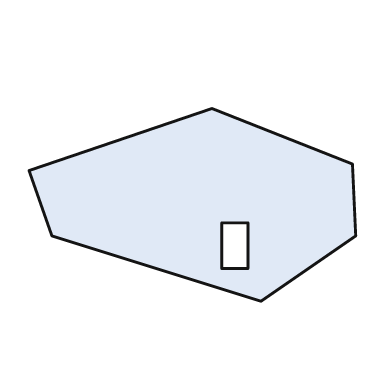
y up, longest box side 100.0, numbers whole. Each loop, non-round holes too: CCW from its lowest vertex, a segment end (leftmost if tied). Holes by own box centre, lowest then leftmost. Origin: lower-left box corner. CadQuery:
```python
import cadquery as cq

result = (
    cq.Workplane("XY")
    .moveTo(71.0, 0.0)
    .lineTo(100.0, 20.0)
    .lineTo(99.0, 42.0)
    .lineTo(56.0, 59.0)
    .lineTo(0.0, 40.0)
    .lineTo(7.0, 20.0)
    .close()
    .moveTo(59.0, 10.0)
    .lineTo(67.0, 10.0)
    .lineTo(67.0, 24.0)
    .lineTo(59.0, 24.0)
    .close()
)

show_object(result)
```